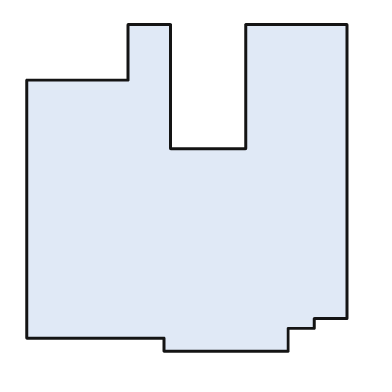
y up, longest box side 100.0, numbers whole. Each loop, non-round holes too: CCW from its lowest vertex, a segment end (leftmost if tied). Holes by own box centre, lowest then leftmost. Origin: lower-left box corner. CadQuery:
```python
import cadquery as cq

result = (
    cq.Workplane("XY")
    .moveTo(42.0, 0.0)
    .lineTo(80.0, 0.0)
    .lineTo(80.0, 7.0)
    .lineTo(88.0, 7.0)
    .lineTo(88.0, 10.0)
    .lineTo(98.0, 10.0)
    .lineTo(98.0, 100.0)
    .lineTo(67.0, 100.0)
    .lineTo(67.0, 62.0)
    .lineTo(44.0, 62.0)
    .lineTo(44.0, 100.0)
    .lineTo(31.0, 100.0)
    .lineTo(31.0, 83.0)
    .lineTo(0.0, 83.0)
    .lineTo(0.0, 4.0)
    .lineTo(42.0, 4.0)
    .close()
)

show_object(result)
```